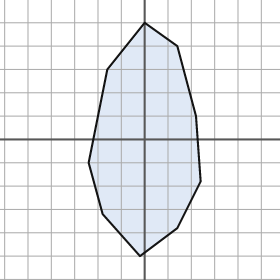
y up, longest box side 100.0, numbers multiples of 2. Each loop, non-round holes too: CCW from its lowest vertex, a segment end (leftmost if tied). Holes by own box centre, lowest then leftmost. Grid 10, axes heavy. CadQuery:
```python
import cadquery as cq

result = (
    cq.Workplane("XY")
    .moveTo(-2.0, -50.0)
    .lineTo(14.0, -38.0)
    .lineTo(24.0, -18.0)
    .lineTo(22.0, 10.0)
    .lineTo(14.0, 40.0)
    .lineTo(0.0, 50.0)
    .lineTo(-16.0, 30.0)
    .lineTo(-24.0, -10.0)
    .lineTo(-18.0, -32.0)
    .close()
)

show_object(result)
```